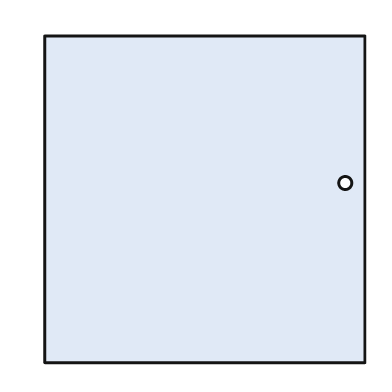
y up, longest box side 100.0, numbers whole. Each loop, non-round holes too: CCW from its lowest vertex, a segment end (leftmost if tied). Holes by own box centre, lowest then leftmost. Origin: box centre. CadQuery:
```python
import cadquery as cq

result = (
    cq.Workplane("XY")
    .moveTo(-49.0, -50.0)
    .lineTo(49.0, -50.0)
    .lineTo(49.0, 50.0)
    .lineTo(-49.0, 50.0)
    .close()
    .moveTo(43.0, 5.0)
    .circle(2.0)
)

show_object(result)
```